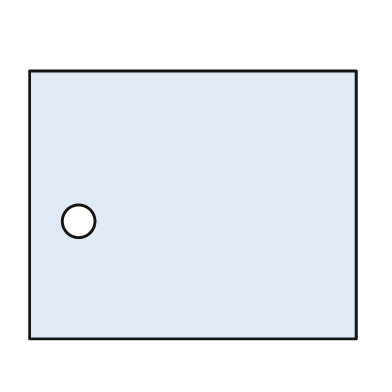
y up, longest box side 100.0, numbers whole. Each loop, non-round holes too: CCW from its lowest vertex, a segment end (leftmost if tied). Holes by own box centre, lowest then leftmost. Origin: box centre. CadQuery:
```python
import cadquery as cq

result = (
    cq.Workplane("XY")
    .moveTo(-50.0, -41.0)
    .lineTo(50.0, -41.0)
    .lineTo(50.0, 41.0)
    .lineTo(-50.0, 41.0)
    .close()
    .moveTo(-35.0, -5.0)
    .circle(5.0)
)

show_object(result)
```